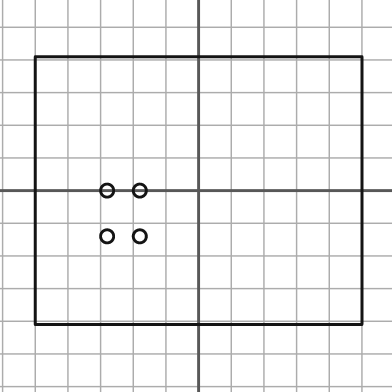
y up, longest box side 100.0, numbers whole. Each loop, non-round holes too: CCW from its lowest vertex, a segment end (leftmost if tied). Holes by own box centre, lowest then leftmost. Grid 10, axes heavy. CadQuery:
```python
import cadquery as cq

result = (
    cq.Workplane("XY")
    .moveTo(-50.0, -41.0)
    .lineTo(50.0, -41.0)
    .lineTo(50.0, 41.0)
    .lineTo(-50.0, 41.0)
    .close()
    .moveTo(-28.0, -14.0)
    .circle(2.0)
    .moveTo(-18.0, -14.0)
    .circle(2.0)
    .moveTo(-28.0, 0.0)
    .circle(2.0)
    .moveTo(-18.0, 0.0)
    .circle(2.0)
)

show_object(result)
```